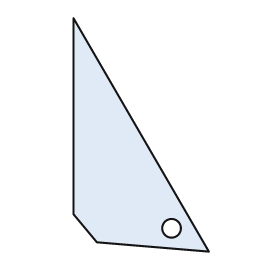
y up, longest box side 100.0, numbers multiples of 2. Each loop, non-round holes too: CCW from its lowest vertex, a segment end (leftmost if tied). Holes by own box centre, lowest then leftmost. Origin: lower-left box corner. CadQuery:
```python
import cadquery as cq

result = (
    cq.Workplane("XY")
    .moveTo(58.0, 0.0)
    .lineTo(0.0, 100.0)
    .lineTo(0.0, 16.0)
    .lineTo(10.0, 4.0)
    .close()
    .moveTo(42.0, 10.0)
    .circle(4.0)
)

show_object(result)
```